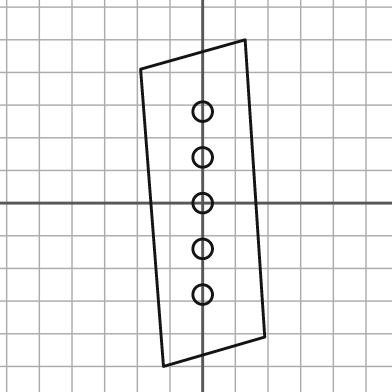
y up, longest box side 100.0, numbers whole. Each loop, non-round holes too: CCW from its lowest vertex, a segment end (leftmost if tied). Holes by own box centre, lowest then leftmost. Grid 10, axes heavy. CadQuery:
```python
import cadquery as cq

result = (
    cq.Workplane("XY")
    .moveTo(-12.0, -50.0)
    .lineTo(19.0, -41.0)
    .lineTo(13.0, 50.0)
    .lineTo(-19.0, 41.0)
    .close()
    .moveTo(0.0, -28.0)
    .circle(3.0)
    .moveTo(0.0, -14.0)
    .circle(3.0)
    .moveTo(0.0, 0.0)
    .circle(3.0)
    .moveTo(0.0, 14.0)
    .circle(3.0)
    .moveTo(0.0, 28.0)
    .circle(3.0)
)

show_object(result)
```